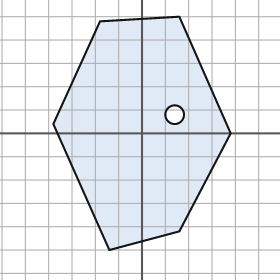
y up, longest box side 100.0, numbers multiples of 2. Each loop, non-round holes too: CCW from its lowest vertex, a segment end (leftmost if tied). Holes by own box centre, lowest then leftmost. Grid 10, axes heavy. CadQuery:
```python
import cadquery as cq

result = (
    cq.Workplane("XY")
    .moveTo(-14.0, -50.0)
    .lineTo(16.0, -42.0)
    .lineTo(38.0, 0.0)
    .lineTo(16.0, 50.0)
    .lineTo(-18.0, 48.0)
    .lineTo(-38.0, 4.0)
    .close()
    .moveTo(14.0, 8.0)
    .circle(4.0)
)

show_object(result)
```